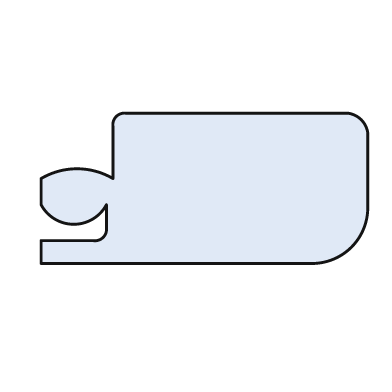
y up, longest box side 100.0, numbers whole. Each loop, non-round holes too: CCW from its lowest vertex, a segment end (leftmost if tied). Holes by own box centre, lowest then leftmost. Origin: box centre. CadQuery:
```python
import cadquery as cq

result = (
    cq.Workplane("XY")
    .moveTo(-50.0, -23.0)
    .lineTo(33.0, -23.0)
    .threePointArc((45.0, -18.0), (50.0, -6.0))
    .lineTo(50.0, 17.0)
    .threePointArc((48.0, 21.0), (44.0, 23.0))
    .lineTo(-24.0, 23.0)
    .threePointArc((-27.0, 22.0), (-28.0, 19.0))
    .lineTo(-28.0, 3.0)
    .threePointArc((-39.0, 6.0), (-50.0, 3.0))
    .lineTo(-50.0, -5.0)
    .threePointArc((-40.0, -11.0), (-30.0, -5.0))
    .lineTo(-30.0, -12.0)
    .threePointArc((-31.0, -15.0), (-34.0, -16.0))
    .lineTo(-50.0, -16.0)
    .close()
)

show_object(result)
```